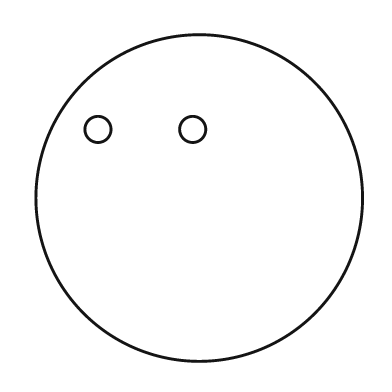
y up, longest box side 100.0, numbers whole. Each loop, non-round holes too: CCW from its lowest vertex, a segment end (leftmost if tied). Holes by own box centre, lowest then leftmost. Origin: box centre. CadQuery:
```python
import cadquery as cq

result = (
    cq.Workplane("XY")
    .moveTo(0.0, 0.0)
    .circle(50.0)
    .moveTo(-31.0, 21.0)
    .circle(4.0)
    .moveTo(-2.0, 21.0)
    .circle(4.0)
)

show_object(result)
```